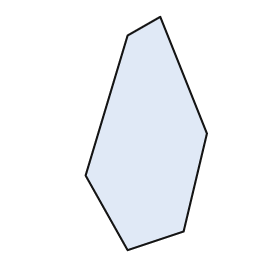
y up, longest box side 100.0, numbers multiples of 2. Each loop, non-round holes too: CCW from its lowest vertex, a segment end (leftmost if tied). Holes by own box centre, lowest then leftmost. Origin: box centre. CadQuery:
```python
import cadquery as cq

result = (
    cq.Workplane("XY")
    .moveTo(-8.0, -50.0)
    .lineTo(16.0, -42.0)
    .lineTo(26.0, 0.0)
    .lineTo(6.0, 50.0)
    .lineTo(-8.0, 42.0)
    .lineTo(-26.0, -18.0)
    .close()
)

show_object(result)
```